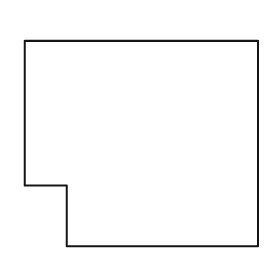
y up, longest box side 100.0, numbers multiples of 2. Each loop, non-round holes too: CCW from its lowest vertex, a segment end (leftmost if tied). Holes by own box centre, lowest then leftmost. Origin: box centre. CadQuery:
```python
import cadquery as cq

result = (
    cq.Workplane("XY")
    .moveTo(-32.0, -44.0)
    .lineTo(50.0, -44.0)
    .lineTo(50.0, 44.0)
    .lineTo(-50.0, 44.0)
    .lineTo(-50.0, -18.0)
    .lineTo(-32.0, -18.0)
    .close()
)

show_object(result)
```